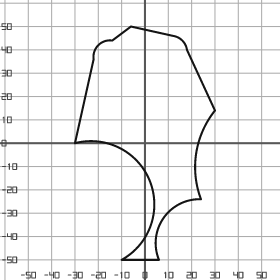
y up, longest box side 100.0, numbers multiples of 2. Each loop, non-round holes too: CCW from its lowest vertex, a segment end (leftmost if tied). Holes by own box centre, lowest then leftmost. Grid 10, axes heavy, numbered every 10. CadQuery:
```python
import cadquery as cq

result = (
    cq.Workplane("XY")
    .moveTo(-10.0, -50.0)
    .lineTo(6.0, -50.0)
    .threePointArc((8.0, -32.0), (24.0, -24.0))
    .threePointArc((22.0, -4.0), (30.0, 14.0))
    .lineTo(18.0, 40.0)
    .threePointArc((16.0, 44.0), (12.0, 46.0))
    .lineTo(-6.0, 50.0)
    .lineTo(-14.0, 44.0)
    .threePointArc((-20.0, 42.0), (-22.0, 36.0))
    .lineTo(-30.0, 0.0)
    .threePointArc((2.0, -16.0), (-10.0, -50.0))
    .close()
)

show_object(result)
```